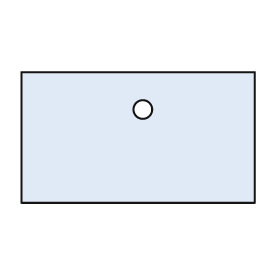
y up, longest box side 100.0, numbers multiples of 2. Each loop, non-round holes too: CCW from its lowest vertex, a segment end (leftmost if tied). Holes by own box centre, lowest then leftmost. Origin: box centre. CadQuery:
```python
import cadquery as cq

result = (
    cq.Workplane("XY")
    .moveTo(-50.0, -28.0)
    .lineTo(50.0, -28.0)
    .lineTo(50.0, 28.0)
    .lineTo(-50.0, 28.0)
    .close()
    .moveTo(2.0, 12.0)
    .circle(4.0)
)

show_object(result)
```